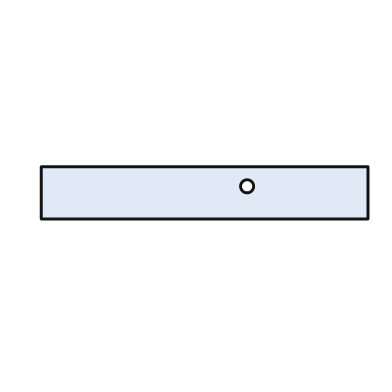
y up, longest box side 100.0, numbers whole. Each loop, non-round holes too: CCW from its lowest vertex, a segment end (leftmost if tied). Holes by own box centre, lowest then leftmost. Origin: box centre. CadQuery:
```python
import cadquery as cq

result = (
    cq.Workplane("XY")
    .moveTo(-50.0, -8.0)
    .lineTo(50.0, -8.0)
    .lineTo(50.0, 8.0)
    .lineTo(-50.0, 8.0)
    .close()
    .moveTo(13.0, 2.0)
    .circle(2.0)
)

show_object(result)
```